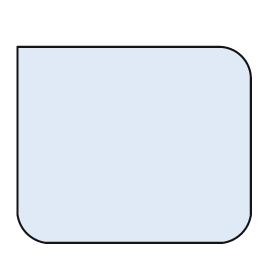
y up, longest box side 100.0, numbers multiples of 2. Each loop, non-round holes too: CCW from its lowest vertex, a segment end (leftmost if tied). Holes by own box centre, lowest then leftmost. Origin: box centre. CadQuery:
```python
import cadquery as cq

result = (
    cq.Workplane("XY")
    .moveTo(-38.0, -42.0)
    .lineTo(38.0, -42.0)
    .threePointArc((46.0, -38.0), (50.0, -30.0))
    .lineTo(50.0, 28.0)
    .threePointArc((46.0, 38.0), (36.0, 42.0))
    .lineTo(-50.0, 42.0)
    .lineTo(-50.0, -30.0)
    .threePointArc((-46.0, -38.0), (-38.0, -42.0))
    .close()
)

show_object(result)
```